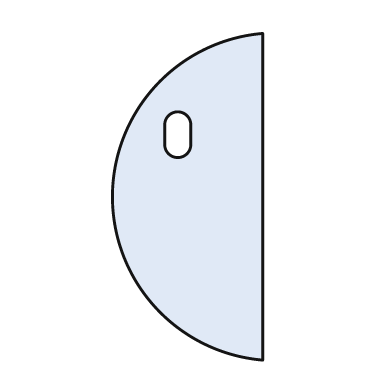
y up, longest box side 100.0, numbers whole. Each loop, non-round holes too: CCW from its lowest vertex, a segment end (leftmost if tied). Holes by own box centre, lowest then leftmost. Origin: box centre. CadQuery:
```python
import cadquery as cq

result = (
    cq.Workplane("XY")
    .moveTo(23.0, -50.0)
    .lineTo(23.0, 50.0)
    .threePointArc((-23.0, 0.0), (23.0, -50.0))
    .close()
    .moveTo(-7.0, 16.0)
    .threePointArc((-3.0, 12.0), (1.0, 16.0))
    .lineTo(1.0, 22.0)
    .threePointArc((-3.0, 26.0), (-7.0, 22.0))
    .close()
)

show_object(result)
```